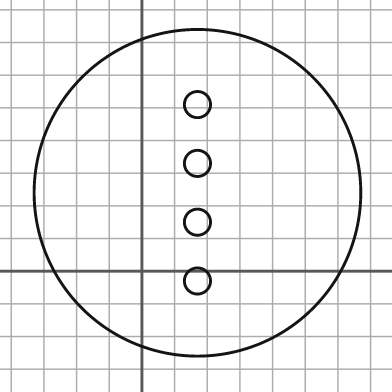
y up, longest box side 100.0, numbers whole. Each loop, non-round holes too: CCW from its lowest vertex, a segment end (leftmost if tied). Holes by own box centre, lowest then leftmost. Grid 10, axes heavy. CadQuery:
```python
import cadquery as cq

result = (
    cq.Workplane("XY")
    .moveTo(17.0, 24.0)
    .circle(50.0)
    .moveTo(17.0, -3.0)
    .circle(4.0)
    .moveTo(17.0, 15.0)
    .circle(4.0)
    .moveTo(17.0, 33.0)
    .circle(4.0)
    .moveTo(17.0, 51.0)
    .circle(4.0)
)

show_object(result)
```